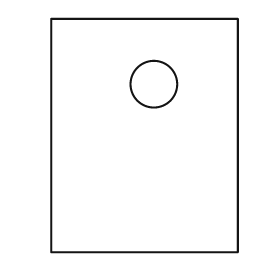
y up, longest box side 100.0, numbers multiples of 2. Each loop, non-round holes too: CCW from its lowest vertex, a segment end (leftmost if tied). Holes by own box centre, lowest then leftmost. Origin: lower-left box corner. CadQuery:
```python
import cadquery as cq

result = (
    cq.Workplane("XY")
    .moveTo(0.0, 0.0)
    .lineTo(80.0, 0.0)
    .lineTo(80.0, 100.0)
    .lineTo(0.0, 100.0)
    .close()
    .moveTo(44.0, 72.0)
    .circle(10.0)
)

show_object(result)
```